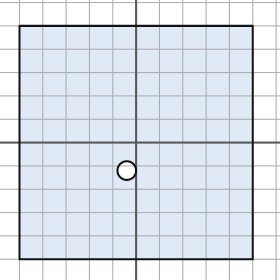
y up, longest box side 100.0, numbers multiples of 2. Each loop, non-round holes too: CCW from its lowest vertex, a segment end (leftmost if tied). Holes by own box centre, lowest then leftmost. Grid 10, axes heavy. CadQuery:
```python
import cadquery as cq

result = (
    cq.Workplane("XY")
    .moveTo(-50.0, -50.0)
    .lineTo(50.0, -50.0)
    .lineTo(50.0, 50.0)
    .lineTo(-50.0, 50.0)
    .close()
    .moveTo(-4.0, -12.0)
    .circle(4.0)
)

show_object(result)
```